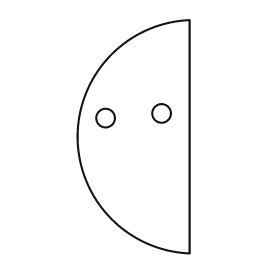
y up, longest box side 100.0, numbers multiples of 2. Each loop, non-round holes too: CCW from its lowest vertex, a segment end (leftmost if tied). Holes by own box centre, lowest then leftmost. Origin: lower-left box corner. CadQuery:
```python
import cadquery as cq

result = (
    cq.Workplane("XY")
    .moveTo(48.0, 0.0)
    .lineTo(48.0, 100.0)
    .threePointArc((0.0, 50.0), (48.0, 0.0))
    .close()
    .moveTo(12.0, 58.0)
    .circle(4.0)
    .moveTo(36.0, 60.0)
    .circle(4.0)
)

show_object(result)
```